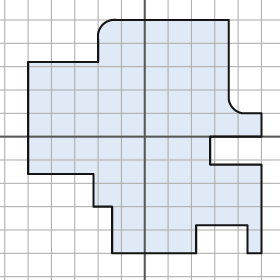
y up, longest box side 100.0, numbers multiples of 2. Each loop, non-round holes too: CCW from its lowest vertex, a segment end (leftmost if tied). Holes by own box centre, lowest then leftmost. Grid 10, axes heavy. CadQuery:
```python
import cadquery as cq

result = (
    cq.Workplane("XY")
    .moveTo(-14.0, -50.0)
    .lineTo(22.0, -50.0)
    .lineTo(22.0, -38.0)
    .lineTo(44.0, -38.0)
    .lineTo(44.0, -50.0)
    .lineTo(50.0, -50.0)
    .lineTo(50.0, -12.0)
    .lineTo(28.0, -12.0)
    .lineTo(28.0, 0.0)
    .lineTo(50.0, 0.0)
    .lineTo(50.0, 10.0)
    .lineTo(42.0, 10.0)
    .threePointArc((38.0, 12.0), (36.0, 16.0))
    .lineTo(36.0, 50.0)
    .lineTo(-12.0, 50.0)
    .threePointArc((-18.0, 48.0), (-20.0, 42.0))
    .lineTo(-20.0, 32.0)
    .lineTo(-50.0, 32.0)
    .lineTo(-50.0, -16.0)
    .lineTo(-22.0, -16.0)
    .lineTo(-22.0, -30.0)
    .lineTo(-14.0, -30.0)
    .close()
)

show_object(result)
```